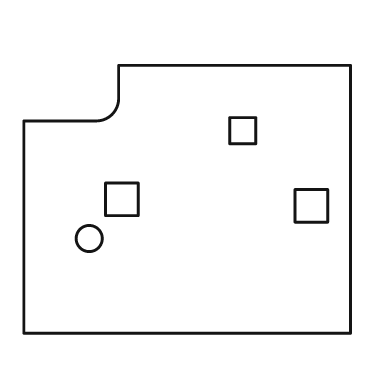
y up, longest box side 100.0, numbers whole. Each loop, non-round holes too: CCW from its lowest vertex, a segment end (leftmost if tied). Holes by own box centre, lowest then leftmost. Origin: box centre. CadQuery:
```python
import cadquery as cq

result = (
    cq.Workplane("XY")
    .moveTo(-50.0, -41.0)
    .lineTo(50.0, -41.0)
    .lineTo(50.0, 41.0)
    .lineTo(-21.0, 41.0)
    .lineTo(-21.0, 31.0)
    .threePointArc((-23.0, 26.0), (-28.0, 24.0))
    .lineTo(-50.0, 24.0)
    .close()
    .moveTo(-30.0, -12.0)
    .circle(4.0)
    .moveTo(33.0, -7.0)
    .lineTo(43.0, -7.0)
    .lineTo(43.0, 3.0)
    .lineTo(33.0, 3.0)
    .close()
    .moveTo(-25.0, -5.0)
    .lineTo(-15.0, -5.0)
    .lineTo(-15.0, 5.0)
    .lineTo(-25.0, 5.0)
    .close()
    .moveTo(13.0, 17.0)
    .lineTo(21.0, 17.0)
    .lineTo(21.0, 25.0)
    .lineTo(13.0, 25.0)
    .close()
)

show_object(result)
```